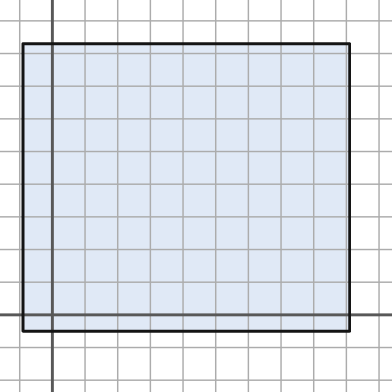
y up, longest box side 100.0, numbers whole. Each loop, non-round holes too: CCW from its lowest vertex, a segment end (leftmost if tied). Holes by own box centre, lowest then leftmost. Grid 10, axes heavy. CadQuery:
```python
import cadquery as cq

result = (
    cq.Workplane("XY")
    .moveTo(-9.0, -5.0)
    .lineTo(91.0, -5.0)
    .lineTo(91.0, 83.0)
    .lineTo(-9.0, 83.0)
    .close()
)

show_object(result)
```